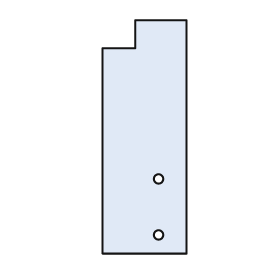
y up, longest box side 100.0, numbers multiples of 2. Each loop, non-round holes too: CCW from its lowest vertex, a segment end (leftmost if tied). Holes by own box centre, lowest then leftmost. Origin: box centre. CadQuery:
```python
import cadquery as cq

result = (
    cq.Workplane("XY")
    .moveTo(-18.0, -50.0)
    .lineTo(18.0, -50.0)
    .lineTo(18.0, 50.0)
    .lineTo(-4.0, 50.0)
    .lineTo(-4.0, 38.0)
    .lineTo(-18.0, 38.0)
    .close()
    .moveTo(6.0, -42.0)
    .circle(2.0)
    .moveTo(6.0, -18.0)
    .circle(2.0)
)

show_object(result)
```